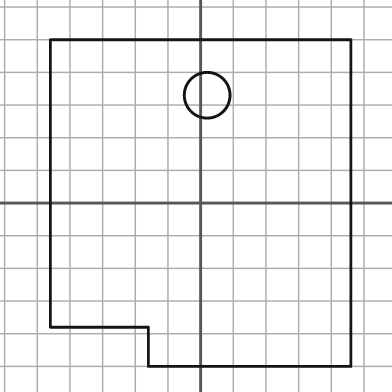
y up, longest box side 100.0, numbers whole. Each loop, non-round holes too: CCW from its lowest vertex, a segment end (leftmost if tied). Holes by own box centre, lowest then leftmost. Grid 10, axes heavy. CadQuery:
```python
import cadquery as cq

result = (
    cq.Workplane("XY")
    .moveTo(-16.0, -50.0)
    .lineTo(46.0, -50.0)
    .lineTo(46.0, 50.0)
    .lineTo(-46.0, 50.0)
    .lineTo(-46.0, -38.0)
    .lineTo(-16.0, -38.0)
    .close()
    .moveTo(2.0, 33.0)
    .circle(7.0)
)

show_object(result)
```